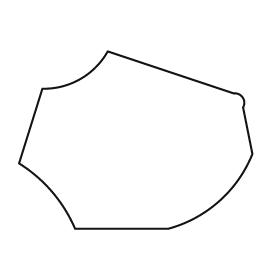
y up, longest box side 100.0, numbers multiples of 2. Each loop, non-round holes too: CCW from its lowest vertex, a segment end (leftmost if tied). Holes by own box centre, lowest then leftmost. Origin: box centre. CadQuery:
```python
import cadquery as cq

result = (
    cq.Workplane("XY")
    .moveTo(-26.0, -38.0)
    .lineTo(14.0, -38.0)
    .threePointArc((36.0, -26.0), (50.0, -6.0))
    .lineTo(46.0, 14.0)
    .threePointArc((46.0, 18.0), (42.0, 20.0))
    .lineTo(-12.0, 38.0)
    .threePointArc((-24.0, 26.0), (-40.0, 22.0))
    .lineTo(-50.0, -10.0)
    .threePointArc((-36.0, -22.0), (-26.0, -38.0))
    .close()
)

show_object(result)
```